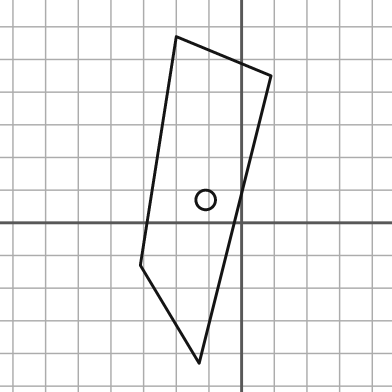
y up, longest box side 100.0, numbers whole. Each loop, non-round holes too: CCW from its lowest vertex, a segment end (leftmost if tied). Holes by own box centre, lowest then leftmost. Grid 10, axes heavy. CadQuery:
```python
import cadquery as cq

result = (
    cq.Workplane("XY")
    .moveTo(-13.0, -43.0)
    .lineTo(9.0, 45.0)
    .lineTo(-20.0, 57.0)
    .lineTo(-31.0, -13.0)
    .close()
    .moveTo(-11.0, 7.0)
    .circle(3.0)
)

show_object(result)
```